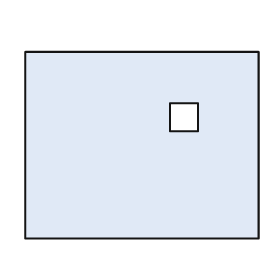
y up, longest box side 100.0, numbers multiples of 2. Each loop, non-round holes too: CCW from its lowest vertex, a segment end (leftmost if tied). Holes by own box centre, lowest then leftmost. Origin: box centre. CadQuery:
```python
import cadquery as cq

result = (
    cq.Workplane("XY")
    .moveTo(-50.0, -40.0)
    .lineTo(50.0, -40.0)
    .lineTo(50.0, 40.0)
    .lineTo(-50.0, 40.0)
    .close()
    .moveTo(12.0, 6.0)
    .lineTo(24.0, 6.0)
    .lineTo(24.0, 18.0)
    .lineTo(12.0, 18.0)
    .close()
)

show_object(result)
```